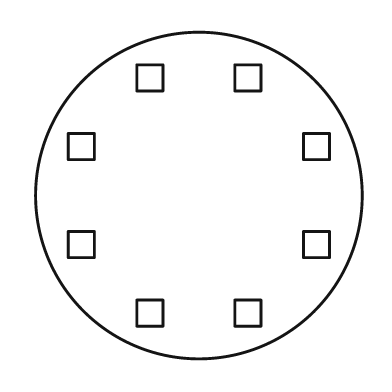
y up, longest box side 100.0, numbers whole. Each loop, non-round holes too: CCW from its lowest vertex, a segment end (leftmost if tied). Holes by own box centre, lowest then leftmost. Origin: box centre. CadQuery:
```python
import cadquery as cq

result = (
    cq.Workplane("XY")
    .moveTo(0.0, 0.0)
    .circle(50.0)
    .moveTo(-19.0, -40.0)
    .lineTo(-11.0, -40.0)
    .lineTo(-11.0, -32.0)
    .lineTo(-19.0, -32.0)
    .close()
    .moveTo(11.0, -40.0)
    .lineTo(19.0, -40.0)
    .lineTo(19.0, -32.0)
    .lineTo(11.0, -32.0)
    .close()
    .moveTo(-40.0, -19.0)
    .lineTo(-32.0, -19.0)
    .lineTo(-32.0, -11.0)
    .lineTo(-40.0, -11.0)
    .close()
    .moveTo(32.0, -19.0)
    .lineTo(40.0, -19.0)
    .lineTo(40.0, -11.0)
    .lineTo(32.0, -11.0)
    .close()
    .moveTo(-40.0, 11.0)
    .lineTo(-32.0, 11.0)
    .lineTo(-32.0, 19.0)
    .lineTo(-40.0, 19.0)
    .close()
    .moveTo(32.0, 11.0)
    .lineTo(40.0, 11.0)
    .lineTo(40.0, 19.0)
    .lineTo(32.0, 19.0)
    .close()
    .moveTo(-19.0, 32.0)
    .lineTo(-11.0, 32.0)
    .lineTo(-11.0, 40.0)
    .lineTo(-19.0, 40.0)
    .close()
    .moveTo(11.0, 32.0)
    .lineTo(19.0, 32.0)
    .lineTo(19.0, 40.0)
    .lineTo(11.0, 40.0)
    .close()
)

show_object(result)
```